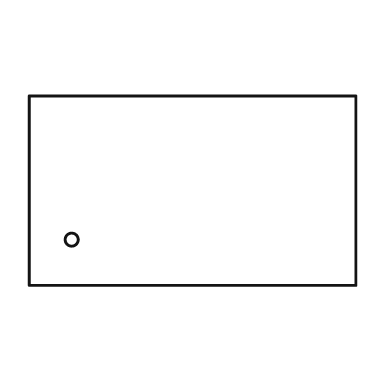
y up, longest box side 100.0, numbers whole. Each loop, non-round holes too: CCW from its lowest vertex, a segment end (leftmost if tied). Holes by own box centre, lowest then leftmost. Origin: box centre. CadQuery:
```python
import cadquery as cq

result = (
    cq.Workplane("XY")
    .moveTo(-50.0, -29.0)
    .lineTo(50.0, -29.0)
    .lineTo(50.0, 29.0)
    .lineTo(-50.0, 29.0)
    .close()
    .moveTo(-37.0, -15.0)
    .circle(2.0)
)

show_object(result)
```